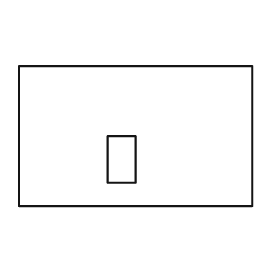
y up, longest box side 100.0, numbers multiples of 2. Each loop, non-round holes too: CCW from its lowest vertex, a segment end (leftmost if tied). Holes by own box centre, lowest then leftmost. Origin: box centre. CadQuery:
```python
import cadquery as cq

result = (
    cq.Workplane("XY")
    .moveTo(-50.0, -30.0)
    .lineTo(50.0, -30.0)
    .lineTo(50.0, 30.0)
    .lineTo(-50.0, 30.0)
    .close()
    .moveTo(-12.0, -20.0)
    .lineTo(0.0, -20.0)
    .lineTo(0.0, 0.0)
    .lineTo(-12.0, 0.0)
    .close()
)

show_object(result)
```